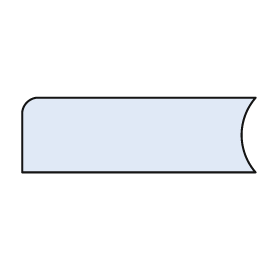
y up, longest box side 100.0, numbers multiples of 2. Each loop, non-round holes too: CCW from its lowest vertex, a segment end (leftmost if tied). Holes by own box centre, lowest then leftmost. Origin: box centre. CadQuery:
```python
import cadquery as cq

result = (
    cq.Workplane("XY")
    .moveTo(-50.0, -16.0)
    .lineTo(50.0, -16.0)
    .threePointArc((44.0, 0.0), (50.0, 16.0))
    .lineTo(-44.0, 16.0)
    .threePointArc((-48.0, 14.0), (-50.0, 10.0))
    .close()
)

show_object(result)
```